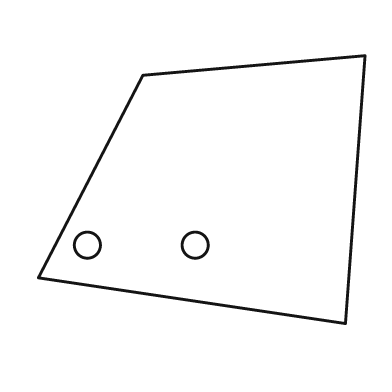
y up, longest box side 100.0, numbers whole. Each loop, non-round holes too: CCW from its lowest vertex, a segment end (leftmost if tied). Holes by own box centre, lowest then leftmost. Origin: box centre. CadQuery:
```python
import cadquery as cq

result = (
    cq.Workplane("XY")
    .moveTo(44.0, -41.0)
    .lineTo(50.0, 41.0)
    .lineTo(-18.0, 35.0)
    .lineTo(-50.0, -27.0)
    .close()
    .moveTo(-35.0, -17.0)
    .circle(4.0)
    .moveTo(-2.0, -17.0)
    .circle(4.0)
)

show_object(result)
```